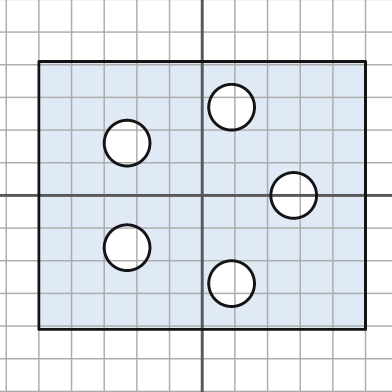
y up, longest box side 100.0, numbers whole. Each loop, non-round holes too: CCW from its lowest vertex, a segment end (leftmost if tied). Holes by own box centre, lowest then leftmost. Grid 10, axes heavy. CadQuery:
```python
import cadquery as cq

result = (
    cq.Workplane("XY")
    .moveTo(-50.0, -41.0)
    .lineTo(50.0, -41.0)
    .lineTo(50.0, 41.0)
    .lineTo(-50.0, 41.0)
    .close()
    .moveTo(9.0, -27.0)
    .circle(7.0)
    .moveTo(-23.0, -16.0)
    .circle(7.0)
    .moveTo(28.0, 0.0)
    .circle(7.0)
    .moveTo(-23.0, 16.0)
    .circle(7.0)
    .moveTo(9.0, 27.0)
    .circle(7.0)
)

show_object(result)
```